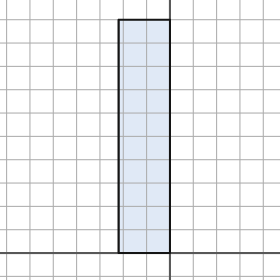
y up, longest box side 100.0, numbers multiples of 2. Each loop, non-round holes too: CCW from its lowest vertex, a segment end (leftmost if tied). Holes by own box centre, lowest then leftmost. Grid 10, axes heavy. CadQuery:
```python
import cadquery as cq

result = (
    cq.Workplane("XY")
    .moveTo(-22.0, 0.0)
    .lineTo(0.0, 0.0)
    .lineTo(0.0, 100.0)
    .lineTo(-22.0, 100.0)
    .close()
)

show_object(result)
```